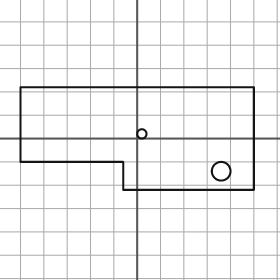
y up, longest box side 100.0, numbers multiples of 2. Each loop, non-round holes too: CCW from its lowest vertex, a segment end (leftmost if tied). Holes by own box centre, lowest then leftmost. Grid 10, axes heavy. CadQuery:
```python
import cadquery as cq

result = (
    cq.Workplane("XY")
    .moveTo(-6.0, -22.0)
    .lineTo(50.0, -22.0)
    .lineTo(50.0, 22.0)
    .lineTo(-50.0, 22.0)
    .lineTo(-50.0, -10.0)
    .lineTo(-6.0, -10.0)
    .close()
    .moveTo(36.0, -14.0)
    .circle(4.0)
    .moveTo(2.0, 2.0)
    .circle(2.0)
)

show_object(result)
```